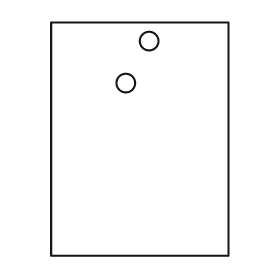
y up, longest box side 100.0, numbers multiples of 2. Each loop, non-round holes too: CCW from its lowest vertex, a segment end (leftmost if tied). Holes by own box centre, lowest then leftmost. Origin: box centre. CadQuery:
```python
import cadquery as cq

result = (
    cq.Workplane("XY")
    .moveTo(-38.0, -50.0)
    .lineTo(38.0, -50.0)
    .lineTo(38.0, 50.0)
    .lineTo(-38.0, 50.0)
    .close()
    .moveTo(-6.0, 24.0)
    .circle(4.0)
    .moveTo(4.0, 42.0)
    .circle(4.0)
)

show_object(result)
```